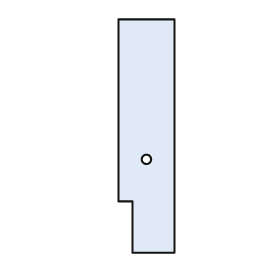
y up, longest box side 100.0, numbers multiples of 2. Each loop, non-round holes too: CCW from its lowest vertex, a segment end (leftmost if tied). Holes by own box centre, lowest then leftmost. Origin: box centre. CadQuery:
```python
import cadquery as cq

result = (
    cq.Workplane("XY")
    .moveTo(-6.0, -50.0)
    .lineTo(12.0, -50.0)
    .lineTo(12.0, 50.0)
    .lineTo(-12.0, 50.0)
    .lineTo(-12.0, -28.0)
    .lineTo(-6.0, -28.0)
    .close()
    .moveTo(0.0, -10.0)
    .circle(2.0)
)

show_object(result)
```